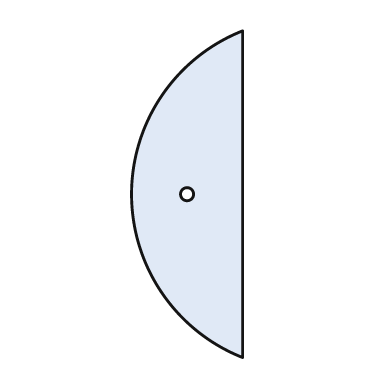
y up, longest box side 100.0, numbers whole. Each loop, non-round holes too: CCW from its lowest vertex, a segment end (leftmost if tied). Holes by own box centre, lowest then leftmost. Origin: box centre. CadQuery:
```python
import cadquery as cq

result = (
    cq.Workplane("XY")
    .moveTo(17.0, -50.0)
    .lineTo(17.0, 50.0)
    .threePointArc((-17.0, 0.0), (17.0, -50.0))
    .close()
    .moveTo(0.0, 0.0)
    .circle(2.0)
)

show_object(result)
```